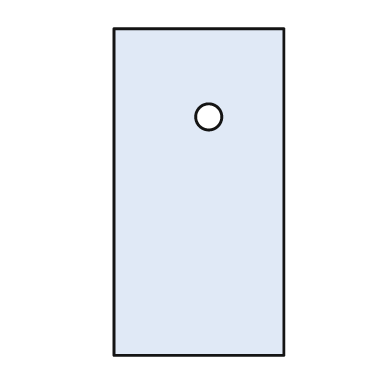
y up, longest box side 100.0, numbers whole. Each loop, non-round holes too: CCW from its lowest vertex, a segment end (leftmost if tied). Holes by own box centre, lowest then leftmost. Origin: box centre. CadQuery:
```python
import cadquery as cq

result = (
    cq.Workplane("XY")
    .moveTo(-26.0, -50.0)
    .lineTo(26.0, -50.0)
    .lineTo(26.0, 50.0)
    .lineTo(-26.0, 50.0)
    .close()
    .moveTo(3.0, 23.0)
    .circle(4.0)
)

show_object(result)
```